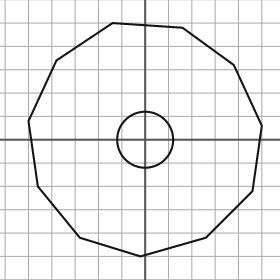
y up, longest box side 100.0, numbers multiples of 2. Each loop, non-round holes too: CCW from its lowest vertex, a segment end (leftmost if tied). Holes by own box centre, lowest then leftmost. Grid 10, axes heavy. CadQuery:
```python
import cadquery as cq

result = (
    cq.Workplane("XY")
    .moveTo(-2.0, -50.0)
    .lineTo(26.0, -42.0)
    .lineTo(46.0, -22.0)
    .lineTo(50.0, 6.0)
    .lineTo(38.0, 32.0)
    .lineTo(16.0, 48.0)
    .lineTo(-14.0, 50.0)
    .lineTo(-38.0, 34.0)
    .lineTo(-50.0, 8.0)
    .lineTo(-46.0, -20.0)
    .lineTo(-28.0, -42.0)
    .close()
    .moveTo(0.0, 0.0)
    .circle(12.0)
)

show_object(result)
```